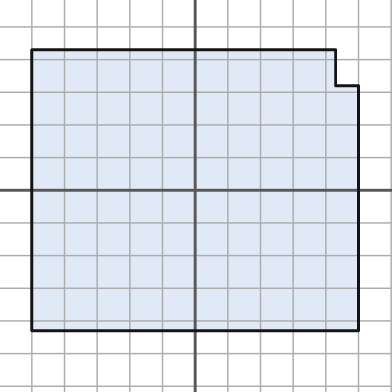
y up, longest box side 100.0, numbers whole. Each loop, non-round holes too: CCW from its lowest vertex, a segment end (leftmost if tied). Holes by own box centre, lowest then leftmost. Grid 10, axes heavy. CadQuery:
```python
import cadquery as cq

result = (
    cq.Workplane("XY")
    .moveTo(-50.0, -43.0)
    .lineTo(50.0, -43.0)
    .lineTo(50.0, 32.0)
    .lineTo(43.0, 32.0)
    .lineTo(43.0, 43.0)
    .lineTo(-50.0, 43.0)
    .close()
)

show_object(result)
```